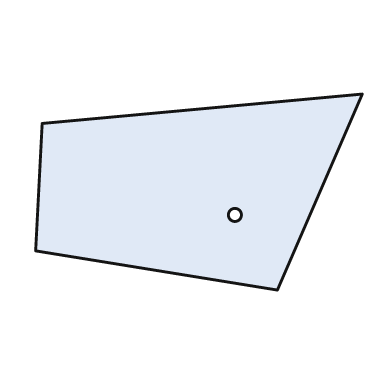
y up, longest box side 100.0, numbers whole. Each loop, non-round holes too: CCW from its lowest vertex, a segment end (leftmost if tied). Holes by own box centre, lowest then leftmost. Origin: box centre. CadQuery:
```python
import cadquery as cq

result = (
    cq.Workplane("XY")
    .moveTo(24.0, -30.0)
    .lineTo(50.0, 30.0)
    .lineTo(-48.0, 21.0)
    .lineTo(-50.0, -18.0)
    .close()
    .moveTo(11.0, -7.0)
    .circle(2.0)
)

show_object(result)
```